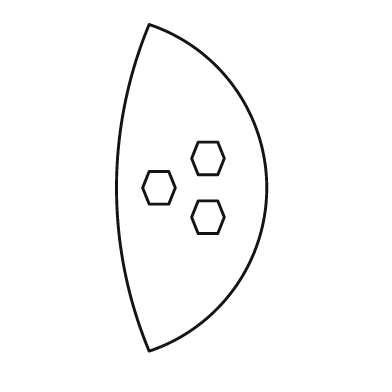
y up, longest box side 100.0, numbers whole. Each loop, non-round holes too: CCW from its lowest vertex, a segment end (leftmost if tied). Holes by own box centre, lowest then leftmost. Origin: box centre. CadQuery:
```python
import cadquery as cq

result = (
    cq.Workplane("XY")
    .moveTo(-13.0, -50.0)
    .threePointArc((23.0, 0.0), (-13.0, 50.0))
    .threePointArc((-23.0, 0.0), (-13.0, -50.0))
    .close()
    .moveTo(2.0, -14.0)
    .lineTo(8.0, -14.0)
    .lineTo(10.0, -9.0)
    .lineTo(8.0, -4.0)
    .lineTo(2.0, -4.0)
    .lineTo(0.0, -9.0)
    .close()
    .moveTo(-13.0, -5.0)
    .lineTo(-7.0, -5.0)
    .lineTo(-5.0, 0.0)
    .lineTo(-7.0, 5.0)
    .lineTo(-13.0, 5.0)
    .lineTo(-15.0, 0.0)
    .close()
    .moveTo(2.0, 4.0)
    .lineTo(8.0, 4.0)
    .lineTo(10.0, 9.0)
    .lineTo(8.0, 14.0)
    .lineTo(2.0, 14.0)
    .lineTo(0.0, 9.0)
    .close()
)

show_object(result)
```